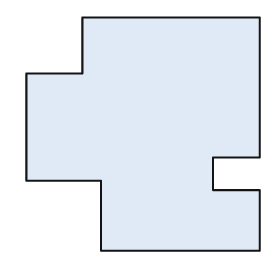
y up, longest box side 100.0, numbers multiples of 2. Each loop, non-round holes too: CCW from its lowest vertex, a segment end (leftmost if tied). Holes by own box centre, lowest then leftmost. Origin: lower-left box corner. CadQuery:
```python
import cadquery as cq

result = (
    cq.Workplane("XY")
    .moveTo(32.0, 0.0)
    .lineTo(100.0, 0.0)
    .lineTo(100.0, 26.0)
    .lineTo(80.0, 26.0)
    .lineTo(80.0, 40.0)
    .lineTo(100.0, 40.0)
    .lineTo(100.0, 100.0)
    .lineTo(24.0, 100.0)
    .lineTo(24.0, 76.0)
    .lineTo(0.0, 76.0)
    .lineTo(0.0, 30.0)
    .lineTo(32.0, 30.0)
    .close()
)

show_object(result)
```